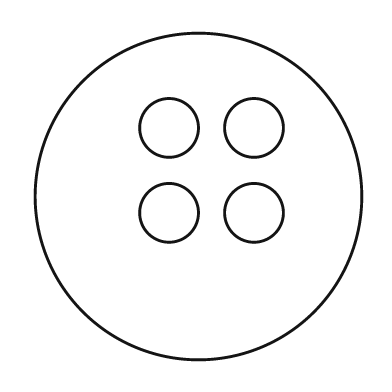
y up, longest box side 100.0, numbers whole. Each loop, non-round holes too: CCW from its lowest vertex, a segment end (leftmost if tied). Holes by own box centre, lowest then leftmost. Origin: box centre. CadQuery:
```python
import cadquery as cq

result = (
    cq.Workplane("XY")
    .moveTo(0.0, 0.0)
    .circle(50.0)
    .moveTo(-9.0, -5.0)
    .circle(9.0)
    .moveTo(17.0, -5.0)
    .circle(9.0)
    .moveTo(-9.0, 21.0)
    .circle(9.0)
    .moveTo(17.0, 21.0)
    .circle(9.0)
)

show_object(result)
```